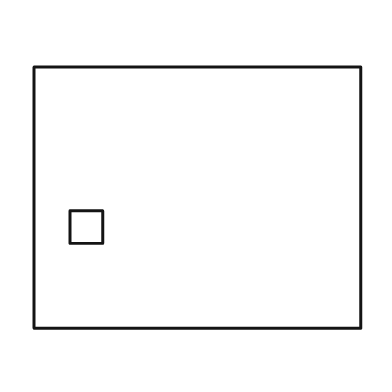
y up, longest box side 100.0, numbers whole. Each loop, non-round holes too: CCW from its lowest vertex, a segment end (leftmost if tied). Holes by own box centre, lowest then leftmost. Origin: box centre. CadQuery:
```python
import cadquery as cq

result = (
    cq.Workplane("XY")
    .moveTo(-50.0, -40.0)
    .lineTo(50.0, -40.0)
    .lineTo(50.0, 40.0)
    .lineTo(-50.0, 40.0)
    .close()
    .moveTo(-39.0, -14.0)
    .lineTo(-29.0, -14.0)
    .lineTo(-29.0, -4.0)
    .lineTo(-39.0, -4.0)
    .close()
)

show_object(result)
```